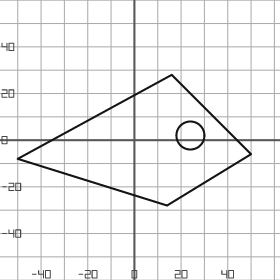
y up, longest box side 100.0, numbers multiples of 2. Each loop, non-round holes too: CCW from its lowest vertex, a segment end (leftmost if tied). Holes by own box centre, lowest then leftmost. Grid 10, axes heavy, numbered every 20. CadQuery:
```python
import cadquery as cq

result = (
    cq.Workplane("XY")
    .moveTo(14.0, -28.0)
    .lineTo(50.0, -6.0)
    .lineTo(16.0, 28.0)
    .lineTo(-50.0, -8.0)
    .close()
    .moveTo(24.0, 2.0)
    .circle(6.0)
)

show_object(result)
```